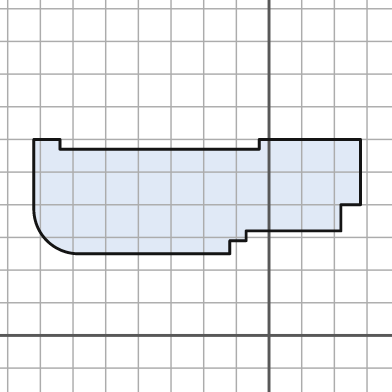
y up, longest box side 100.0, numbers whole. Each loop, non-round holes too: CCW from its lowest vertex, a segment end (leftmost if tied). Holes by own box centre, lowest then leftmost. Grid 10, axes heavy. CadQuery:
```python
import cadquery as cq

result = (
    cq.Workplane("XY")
    .moveTo(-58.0, 25.0)
    .lineTo(-12.0, 25.0)
    .lineTo(-12.0, 29.0)
    .lineTo(-7.0, 29.0)
    .lineTo(-7.0, 32.0)
    .lineTo(22.0, 32.0)
    .lineTo(22.0, 40.0)
    .lineTo(28.0, 40.0)
    .lineTo(28.0, 60.0)
    .lineTo(-3.0, 60.0)
    .lineTo(-3.0, 57.0)
    .lineTo(-64.0, 57.0)
    .lineTo(-64.0, 60.0)
    .lineTo(-72.0, 60.0)
    .lineTo(-72.0, 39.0)
    .threePointArc((-68.0, 29.0), (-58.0, 25.0))
    .close()
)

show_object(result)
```